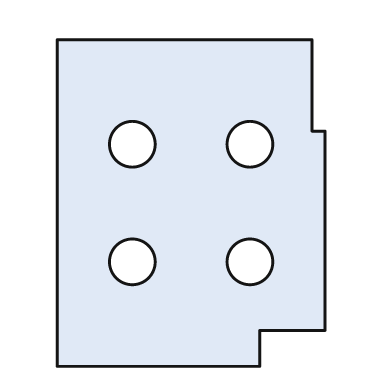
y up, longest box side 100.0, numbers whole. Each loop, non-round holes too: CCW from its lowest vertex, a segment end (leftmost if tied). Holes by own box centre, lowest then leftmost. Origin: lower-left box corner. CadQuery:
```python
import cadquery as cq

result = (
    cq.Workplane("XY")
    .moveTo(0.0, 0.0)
    .lineTo(62.0, 0.0)
    .lineTo(62.0, 11.0)
    .lineTo(82.0, 11.0)
    .lineTo(82.0, 72.0)
    .lineTo(78.0, 72.0)
    .lineTo(78.0, 100.0)
    .lineTo(0.0, 100.0)
    .close()
    .moveTo(23.0, 32.0)
    .circle(7.0)
    .moveTo(59.0, 32.0)
    .circle(7.0)
    .moveTo(23.0, 68.0)
    .circle(7.0)
    .moveTo(59.0, 68.0)
    .circle(7.0)
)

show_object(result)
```